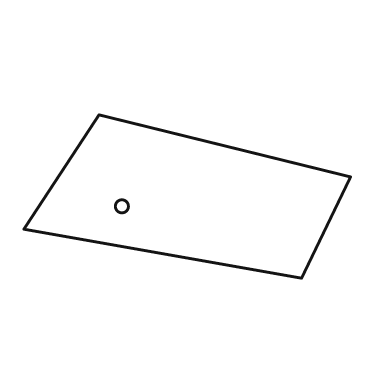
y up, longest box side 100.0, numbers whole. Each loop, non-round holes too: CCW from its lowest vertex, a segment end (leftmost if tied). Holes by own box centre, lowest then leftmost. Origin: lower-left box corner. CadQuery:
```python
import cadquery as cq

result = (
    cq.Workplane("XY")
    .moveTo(85.0, 0.0)
    .lineTo(100.0, 31.0)
    .lineTo(23.0, 50.0)
    .lineTo(0.0, 15.0)
    .close()
    .moveTo(30.0, 22.0)
    .circle(2.0)
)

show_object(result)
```